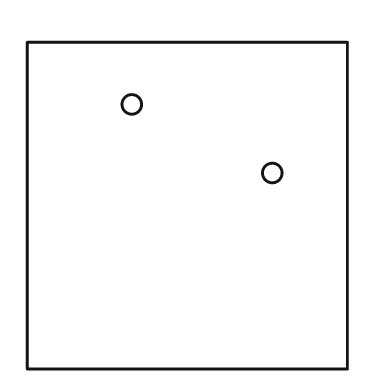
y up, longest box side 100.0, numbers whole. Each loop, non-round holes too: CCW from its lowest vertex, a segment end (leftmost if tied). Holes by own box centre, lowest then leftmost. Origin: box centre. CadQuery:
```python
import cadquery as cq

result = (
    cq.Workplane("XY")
    .moveTo(-49.0, -50.0)
    .lineTo(49.0, -50.0)
    .lineTo(49.0, 50.0)
    .lineTo(-49.0, 50.0)
    .close()
    .moveTo(26.0, 10.0)
    .circle(3.0)
    .moveTo(-17.0, 31.0)
    .circle(3.0)
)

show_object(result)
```